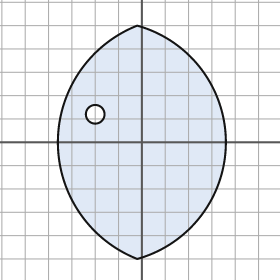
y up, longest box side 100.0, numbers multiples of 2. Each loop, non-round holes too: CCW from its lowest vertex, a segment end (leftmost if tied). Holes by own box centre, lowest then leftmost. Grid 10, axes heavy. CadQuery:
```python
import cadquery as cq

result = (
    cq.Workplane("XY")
    .moveTo(-2.0, -50.0)
    .threePointArc((36.0, 0.0), (-2.0, 50.0))
    .threePointArc((-36.0, 0.0), (-2.0, -50.0))
    .close()
    .moveTo(-20.0, 12.0)
    .circle(4.0)
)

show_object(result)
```